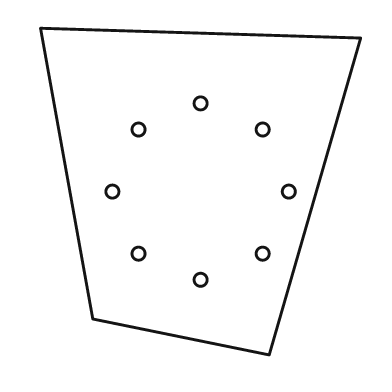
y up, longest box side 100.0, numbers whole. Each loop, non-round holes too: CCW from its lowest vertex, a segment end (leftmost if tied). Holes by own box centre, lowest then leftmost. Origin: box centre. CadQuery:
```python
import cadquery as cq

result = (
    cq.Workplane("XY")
    .moveTo(21.0, -50.0)
    .lineTo(49.0, 47.0)
    .lineTo(-49.0, 50.0)
    .lineTo(-33.0, -39.0)
    .close()
    .moveTo(0.0, -27.0)
    .circle(2.0)
    .moveTo(-19.0, -19.0)
    .circle(2.0)
    .moveTo(19.0, -19.0)
    .circle(2.0)
    .moveTo(-27.0, 0.0)
    .circle(2.0)
    .moveTo(27.0, 0.0)
    .circle(2.0)
    .moveTo(-19.0, 19.0)
    .circle(2.0)
    .moveTo(19.0, 19.0)
    .circle(2.0)
    .moveTo(0.0, 27.0)
    .circle(2.0)
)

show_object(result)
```